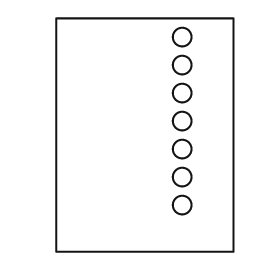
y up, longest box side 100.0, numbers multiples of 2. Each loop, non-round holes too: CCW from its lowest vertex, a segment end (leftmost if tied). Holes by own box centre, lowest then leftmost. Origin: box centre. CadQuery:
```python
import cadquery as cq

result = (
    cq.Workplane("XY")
    .moveTo(-38.0, -50.0)
    .lineTo(38.0, -50.0)
    .lineTo(38.0, 50.0)
    .lineTo(-38.0, 50.0)
    .close()
    .moveTo(16.0, -30.0)
    .circle(4.0)
    .moveTo(16.0, -18.0)
    .circle(4.0)
    .moveTo(16.0, -6.0)
    .circle(4.0)
    .moveTo(16.0, 6.0)
    .circle(4.0)
    .moveTo(16.0, 18.0)
    .circle(4.0)
    .moveTo(16.0, 30.0)
    .circle(4.0)
    .moveTo(16.0, 42.0)
    .circle(4.0)
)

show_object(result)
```